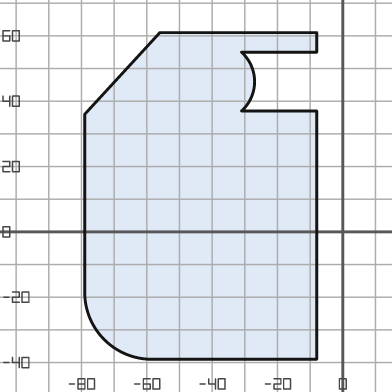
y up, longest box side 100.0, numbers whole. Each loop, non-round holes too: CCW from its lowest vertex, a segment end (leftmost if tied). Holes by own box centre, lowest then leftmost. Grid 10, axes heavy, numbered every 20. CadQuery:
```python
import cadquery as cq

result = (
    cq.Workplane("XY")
    .moveTo(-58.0, -39.0)
    .lineTo(-8.0, -39.0)
    .lineTo(-8.0, 37.0)
    .lineTo(-31.0, 37.0)
    .threePointArc((-27.0, 46.0), (-31.0, 55.0))
    .lineTo(-8.0, 55.0)
    .lineTo(-8.0, 61.0)
    .lineTo(-56.0, 61.0)
    .lineTo(-79.0, 36.0)
    .lineTo(-79.0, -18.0)
    .threePointArc((-73.0, -33.0), (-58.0, -39.0))
    .close()
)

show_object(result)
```